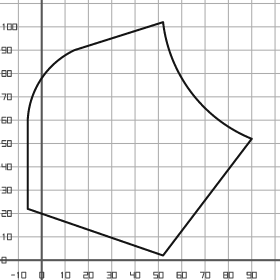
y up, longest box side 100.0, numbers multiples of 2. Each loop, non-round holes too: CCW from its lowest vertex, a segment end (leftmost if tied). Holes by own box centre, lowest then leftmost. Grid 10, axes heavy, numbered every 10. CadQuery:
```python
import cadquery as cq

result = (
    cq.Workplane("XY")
    .moveTo(52.0, 2.0)
    .lineTo(90.0, 52.0)
    .threePointArc((64.0, 72.0), (52.0, 102.0))
    .lineTo(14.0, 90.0)
    .threePointArc((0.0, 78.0), (-6.0, 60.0))
    .lineTo(-6.0, 22.0)
    .close()
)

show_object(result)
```